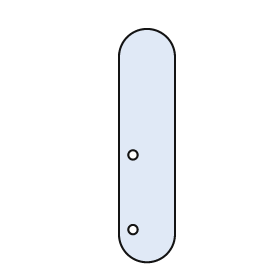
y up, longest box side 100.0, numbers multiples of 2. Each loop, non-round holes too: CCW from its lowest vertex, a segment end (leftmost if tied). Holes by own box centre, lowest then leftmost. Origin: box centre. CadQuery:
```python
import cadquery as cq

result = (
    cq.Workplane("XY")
    .moveTo(-12.0, -38.0)
    .threePointArc((0.0, -50.0), (12.0, -38.0))
    .lineTo(12.0, 38.0)
    .threePointArc((0.0, 50.0), (-12.0, 38.0))
    .close()
    .moveTo(-6.0, -36.0)
    .circle(2.0)
    .moveTo(-6.0, -4.0)
    .circle(2.0)
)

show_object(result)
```